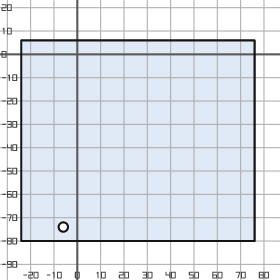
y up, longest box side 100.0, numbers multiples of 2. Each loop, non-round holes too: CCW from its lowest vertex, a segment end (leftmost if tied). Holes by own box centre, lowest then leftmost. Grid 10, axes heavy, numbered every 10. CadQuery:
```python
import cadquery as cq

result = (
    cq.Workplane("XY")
    .moveTo(-24.0, -80.0)
    .lineTo(76.0, -80.0)
    .lineTo(76.0, 6.0)
    .lineTo(-24.0, 6.0)
    .close()
    .moveTo(-6.0, -74.0)
    .circle(2.0)
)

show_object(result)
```